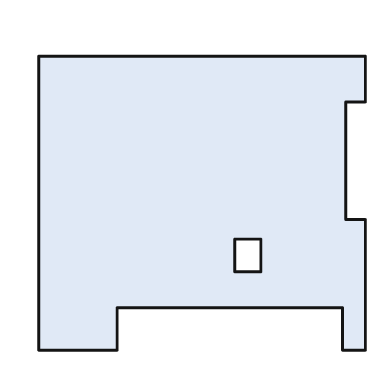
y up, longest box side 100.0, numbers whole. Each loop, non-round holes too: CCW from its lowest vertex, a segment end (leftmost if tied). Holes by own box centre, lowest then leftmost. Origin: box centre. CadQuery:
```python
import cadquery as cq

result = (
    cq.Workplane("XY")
    .moveTo(-50.0, -45.0)
    .lineTo(-26.0, -45.0)
    .lineTo(-26.0, -32.0)
    .lineTo(43.0, -32.0)
    .lineTo(43.0, -45.0)
    .lineTo(50.0, -45.0)
    .lineTo(50.0, -5.0)
    .lineTo(44.0, -5.0)
    .lineTo(44.0, 31.0)
    .lineTo(50.0, 31.0)
    .lineTo(50.0, 45.0)
    .lineTo(-50.0, 45.0)
    .close()
    .moveTo(10.0, -21.0)
    .lineTo(18.0, -21.0)
    .lineTo(18.0, -11.0)
    .lineTo(10.0, -11.0)
    .close()
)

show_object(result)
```